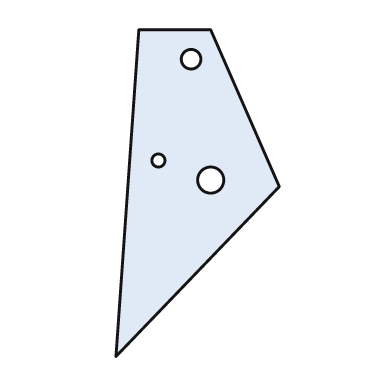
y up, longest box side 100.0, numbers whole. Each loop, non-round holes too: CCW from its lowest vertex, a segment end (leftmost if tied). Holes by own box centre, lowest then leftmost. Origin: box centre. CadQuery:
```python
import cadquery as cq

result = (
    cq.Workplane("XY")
    .moveTo(-25.0, -50.0)
    .lineTo(25.0, 2.0)
    .lineTo(4.0, 50.0)
    .lineTo(-18.0, 50.0)
    .close()
    .moveTo(4.0, 4.0)
    .circle(4.0)
    .moveTo(-12.0, 10.0)
    .circle(2.0)
    .moveTo(-2.0, 41.0)
    .circle(3.0)
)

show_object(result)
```